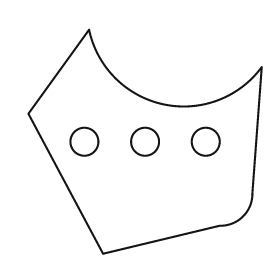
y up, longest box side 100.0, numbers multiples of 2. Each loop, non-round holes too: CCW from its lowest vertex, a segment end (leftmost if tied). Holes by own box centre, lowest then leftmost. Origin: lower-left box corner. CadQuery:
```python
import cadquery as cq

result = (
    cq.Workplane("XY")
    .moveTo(32.0, 0.0)
    .lineTo(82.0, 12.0)
    .threePointArc((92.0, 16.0), (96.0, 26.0))
    .lineTo(100.0, 80.0)
    .threePointArc((58.0, 64.0), (26.0, 96.0))
    .lineTo(0.0, 60.0)
    .close()
    .moveTo(24.0, 48.0)
    .circle(6.0)
    .moveTo(50.0, 48.0)
    .circle(6.0)
    .moveTo(76.0, 48.0)
    .circle(6.0)
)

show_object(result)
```